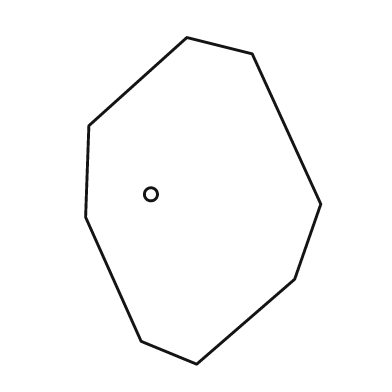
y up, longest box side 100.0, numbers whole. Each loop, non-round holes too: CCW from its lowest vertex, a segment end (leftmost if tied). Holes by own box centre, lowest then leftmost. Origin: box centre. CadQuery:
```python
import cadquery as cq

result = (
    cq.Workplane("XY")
    .moveTo(-2.0, -50.0)
    .lineTo(28.0, -24.0)
    .lineTo(36.0, -1.0)
    .lineTo(15.0, 45.0)
    .lineTo(-5.0, 50.0)
    .lineTo(-35.0, 23.0)
    .lineTo(-36.0, -5.0)
    .lineTo(-19.0, -43.0)
    .close()
    .moveTo(-16.0, 2.0)
    .circle(2.0)
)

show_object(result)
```